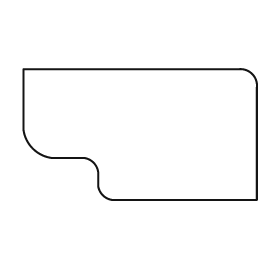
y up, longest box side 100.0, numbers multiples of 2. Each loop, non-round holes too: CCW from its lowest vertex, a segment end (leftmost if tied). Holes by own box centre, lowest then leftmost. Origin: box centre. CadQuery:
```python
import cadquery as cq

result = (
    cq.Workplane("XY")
    .moveTo(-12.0, -28.0)
    .lineTo(50.0, -28.0)
    .lineTo(50.0, 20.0)
    .threePointArc((48.0, 26.0), (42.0, 28.0))
    .lineTo(-50.0, 28.0)
    .lineTo(-50.0, 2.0)
    .threePointArc((-46.0, -6.0), (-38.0, -10.0))
    .lineTo(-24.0, -10.0)
    .threePointArc((-20.0, -12.0), (-18.0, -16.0))
    .lineTo(-18.0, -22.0)
    .threePointArc((-16.0, -26.0), (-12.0, -28.0))
    .close()
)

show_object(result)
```